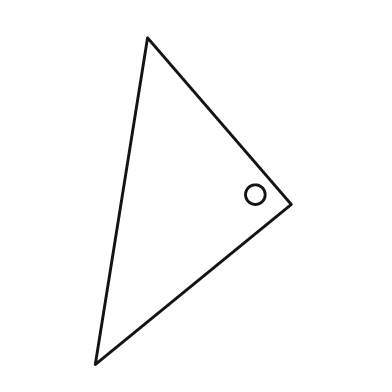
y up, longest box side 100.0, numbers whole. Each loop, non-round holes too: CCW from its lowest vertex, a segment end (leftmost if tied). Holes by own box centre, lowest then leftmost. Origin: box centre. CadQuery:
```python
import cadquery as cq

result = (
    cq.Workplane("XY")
    .moveTo(-30.0, -50.0)
    .lineTo(30.0, -1.0)
    .lineTo(-14.0, 50.0)
    .close()
    .moveTo(19.0, 2.0)
    .circle(3.0)
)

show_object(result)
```